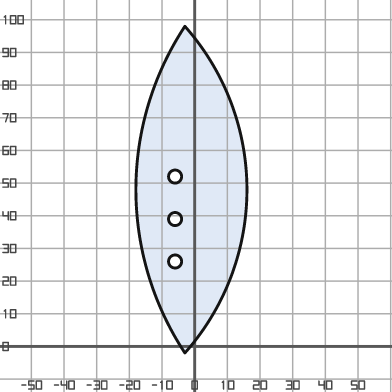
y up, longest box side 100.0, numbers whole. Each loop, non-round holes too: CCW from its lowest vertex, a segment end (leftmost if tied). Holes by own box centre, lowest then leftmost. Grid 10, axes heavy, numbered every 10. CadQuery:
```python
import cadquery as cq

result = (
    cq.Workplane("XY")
    .moveTo(-3.0, -2.0)
    .threePointArc((16.0, 48.0), (-3.0, 98.0))
    .threePointArc((-18.0, 48.0), (-3.0, -2.0))
    .close()
    .moveTo(-6.0, 26.0)
    .circle(2.0)
    .moveTo(-6.0, 39.0)
    .circle(2.0)
    .moveTo(-6.0, 52.0)
    .circle(2.0)
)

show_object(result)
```